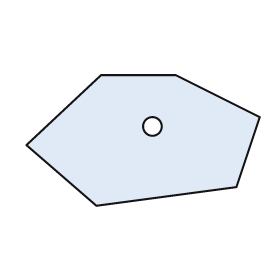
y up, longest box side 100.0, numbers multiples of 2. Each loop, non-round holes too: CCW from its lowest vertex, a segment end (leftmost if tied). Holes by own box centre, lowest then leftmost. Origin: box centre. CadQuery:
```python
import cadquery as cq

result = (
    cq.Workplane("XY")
    .moveTo(-20.0, -28.0)
    .lineTo(40.0, -20.0)
    .lineTo(50.0, 10.0)
    .lineTo(14.0, 28.0)
    .lineTo(-18.0, 28.0)
    .lineTo(-50.0, -2.0)
    .close()
    .moveTo(4.0, 6.0)
    .circle(4.0)
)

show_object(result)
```